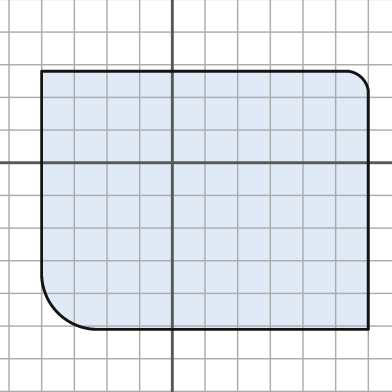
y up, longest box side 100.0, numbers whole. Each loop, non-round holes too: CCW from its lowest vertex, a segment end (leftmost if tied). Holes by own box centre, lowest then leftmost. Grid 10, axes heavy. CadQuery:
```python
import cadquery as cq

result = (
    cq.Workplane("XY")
    .moveTo(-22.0, -51.0)
    .lineTo(60.0, -51.0)
    .lineTo(60.0, 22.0)
    .threePointArc((58.0, 26.0), (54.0, 28.0))
    .lineTo(-40.0, 28.0)
    .lineTo(-40.0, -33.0)
    .threePointArc((-35.0, -46.0), (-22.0, -51.0))
    .close()
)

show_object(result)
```